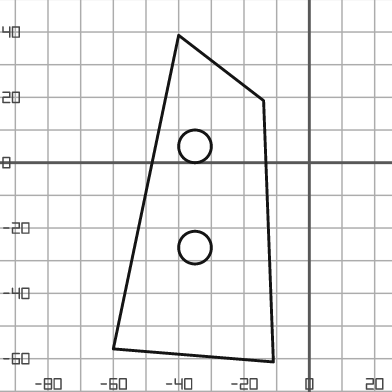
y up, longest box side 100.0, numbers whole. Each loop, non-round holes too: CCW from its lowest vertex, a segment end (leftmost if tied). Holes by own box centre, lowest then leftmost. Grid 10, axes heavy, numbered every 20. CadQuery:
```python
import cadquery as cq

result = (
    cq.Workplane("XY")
    .moveTo(-11.0, -61.0)
    .lineTo(-14.0, 19.0)
    .lineTo(-40.0, 39.0)
    .lineTo(-60.0, -57.0)
    .close()
    .moveTo(-35.0, -26.0)
    .circle(5.0)
    .moveTo(-35.0, 5.0)
    .circle(5.0)
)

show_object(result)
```